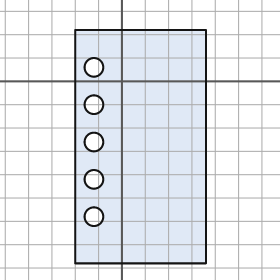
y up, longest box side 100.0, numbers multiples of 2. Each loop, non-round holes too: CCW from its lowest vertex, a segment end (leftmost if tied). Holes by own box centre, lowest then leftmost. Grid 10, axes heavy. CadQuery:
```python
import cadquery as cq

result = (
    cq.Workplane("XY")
    .moveTo(-20.0, -78.0)
    .lineTo(36.0, -78.0)
    .lineTo(36.0, 22.0)
    .lineTo(-20.0, 22.0)
    .close()
    .moveTo(-12.0, -58.0)
    .circle(4.0)
    .moveTo(-12.0, -42.0)
    .circle(4.0)
    .moveTo(-12.0, -26.0)
    .circle(4.0)
    .moveTo(-12.0, -10.0)
    .circle(4.0)
    .moveTo(-12.0, 6.0)
    .circle(4.0)
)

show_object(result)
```